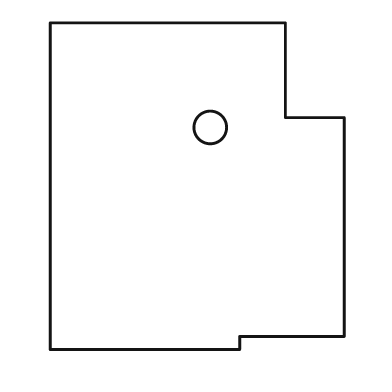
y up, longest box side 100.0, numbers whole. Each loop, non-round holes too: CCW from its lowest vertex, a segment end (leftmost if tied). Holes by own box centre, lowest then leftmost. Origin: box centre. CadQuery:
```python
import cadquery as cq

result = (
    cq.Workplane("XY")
    .moveTo(-45.0, -50.0)
    .lineTo(13.0, -50.0)
    .lineTo(13.0, -46.0)
    .lineTo(45.0, -46.0)
    .lineTo(45.0, 21.0)
    .lineTo(27.0, 21.0)
    .lineTo(27.0, 50.0)
    .lineTo(-45.0, 50.0)
    .close()
    .moveTo(4.0, 18.0)
    .circle(5.0)
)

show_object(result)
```